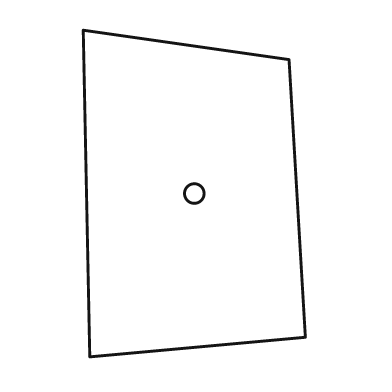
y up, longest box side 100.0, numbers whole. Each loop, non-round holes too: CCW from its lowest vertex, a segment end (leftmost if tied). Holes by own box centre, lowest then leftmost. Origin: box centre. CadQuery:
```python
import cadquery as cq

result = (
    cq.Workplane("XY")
    .moveTo(-32.0, -50.0)
    .lineTo(34.0, -44.0)
    .lineTo(29.0, 41.0)
    .lineTo(-34.0, 50.0)
    .close()
    .moveTo(0.0, 0.0)
    .circle(3.0)
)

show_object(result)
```